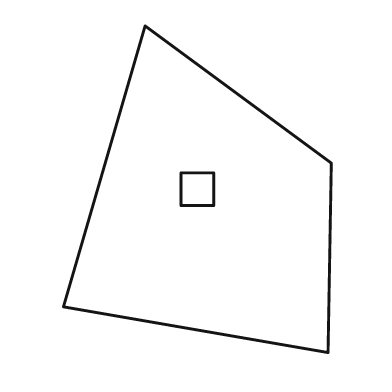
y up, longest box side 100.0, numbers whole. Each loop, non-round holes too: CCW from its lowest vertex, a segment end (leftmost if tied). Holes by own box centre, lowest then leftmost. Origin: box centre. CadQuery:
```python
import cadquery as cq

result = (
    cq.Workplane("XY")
    .moveTo(40.0, -50.0)
    .lineTo(41.0, 8.0)
    .lineTo(-16.0, 50.0)
    .lineTo(-41.0, -36.0)
    .close()
    .moveTo(-5.0, -5.0)
    .lineTo(5.0, -5.0)
    .lineTo(5.0, 5.0)
    .lineTo(-5.0, 5.0)
    .close()
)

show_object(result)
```